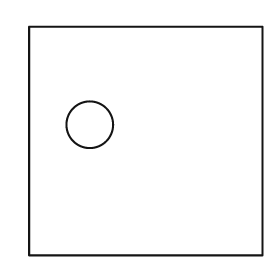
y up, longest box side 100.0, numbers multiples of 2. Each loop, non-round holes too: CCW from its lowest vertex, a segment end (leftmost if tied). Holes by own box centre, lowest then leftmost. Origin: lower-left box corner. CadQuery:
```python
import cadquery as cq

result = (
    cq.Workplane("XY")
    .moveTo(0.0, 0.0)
    .lineTo(100.0, 0.0)
    .lineTo(100.0, 98.0)
    .lineTo(0.0, 98.0)
    .close()
    .moveTo(26.0, 56.0)
    .circle(10.0)
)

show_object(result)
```